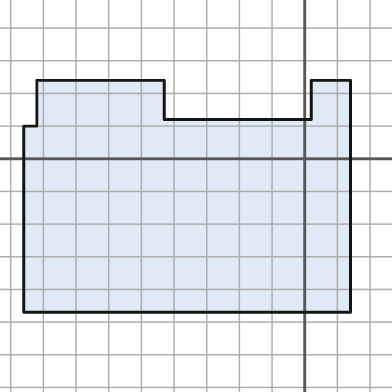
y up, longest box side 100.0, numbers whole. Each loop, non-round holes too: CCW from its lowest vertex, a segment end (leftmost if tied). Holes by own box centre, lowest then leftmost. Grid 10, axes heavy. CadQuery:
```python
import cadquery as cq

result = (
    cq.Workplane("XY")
    .moveTo(-86.0, -47.0)
    .lineTo(14.0, -47.0)
    .lineTo(14.0, 24.0)
    .lineTo(2.0, 24.0)
    .lineTo(2.0, 12.0)
    .lineTo(-43.0, 12.0)
    .lineTo(-43.0, 24.0)
    .lineTo(-82.0, 24.0)
    .lineTo(-82.0, 10.0)
    .lineTo(-86.0, 10.0)
    .close()
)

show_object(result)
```